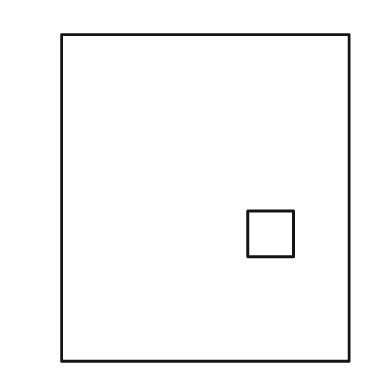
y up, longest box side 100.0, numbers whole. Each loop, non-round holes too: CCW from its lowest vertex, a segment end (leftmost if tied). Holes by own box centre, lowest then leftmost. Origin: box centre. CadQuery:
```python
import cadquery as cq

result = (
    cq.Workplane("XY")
    .moveTo(-44.0, -50.0)
    .lineTo(44.0, -50.0)
    .lineTo(44.0, 50.0)
    .lineTo(-44.0, 50.0)
    .close()
    .moveTo(13.0, -18.0)
    .lineTo(27.0, -18.0)
    .lineTo(27.0, -4.0)
    .lineTo(13.0, -4.0)
    .close()
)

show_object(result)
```